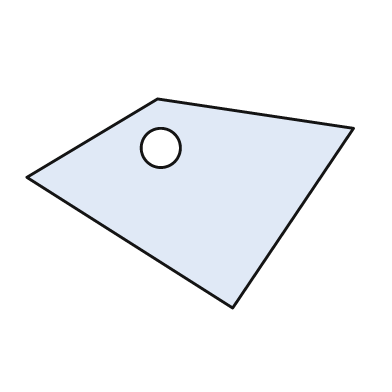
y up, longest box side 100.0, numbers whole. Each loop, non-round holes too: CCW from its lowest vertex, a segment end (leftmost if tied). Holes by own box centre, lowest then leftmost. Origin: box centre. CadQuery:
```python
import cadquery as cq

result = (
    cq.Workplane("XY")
    .moveTo(13.0, -32.0)
    .lineTo(50.0, 23.0)
    .lineTo(-10.0, 32.0)
    .lineTo(-50.0, 8.0)
    .close()
    .moveTo(-9.0, 17.0)
    .circle(6.0)
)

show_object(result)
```